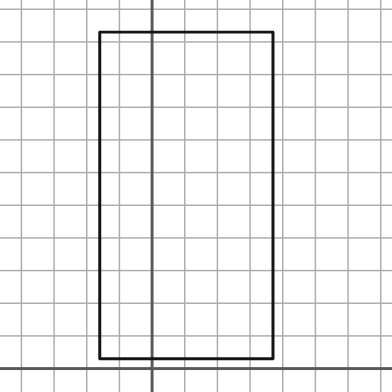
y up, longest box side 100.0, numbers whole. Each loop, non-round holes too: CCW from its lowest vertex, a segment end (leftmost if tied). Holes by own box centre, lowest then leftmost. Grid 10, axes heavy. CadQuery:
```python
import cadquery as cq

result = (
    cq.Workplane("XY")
    .moveTo(-16.0, 3.0)
    .lineTo(37.0, 3.0)
    .lineTo(37.0, 103.0)
    .lineTo(-16.0, 103.0)
    .close()
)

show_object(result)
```